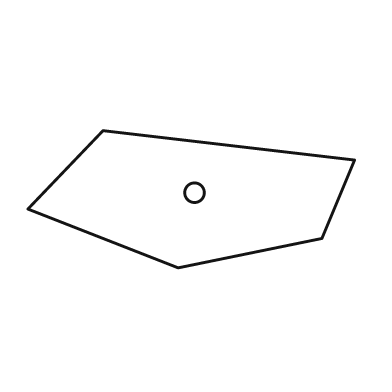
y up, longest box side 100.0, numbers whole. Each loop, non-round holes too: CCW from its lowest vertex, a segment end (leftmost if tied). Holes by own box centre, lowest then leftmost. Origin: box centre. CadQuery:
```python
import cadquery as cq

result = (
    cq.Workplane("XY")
    .moveTo(-4.0, -21.0)
    .lineTo(40.0, -12.0)
    .lineTo(50.0, 12.0)
    .lineTo(-27.0, 21.0)
    .lineTo(-50.0, -3.0)
    .close()
    .moveTo(1.0, 2.0)
    .circle(3.0)
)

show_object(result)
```